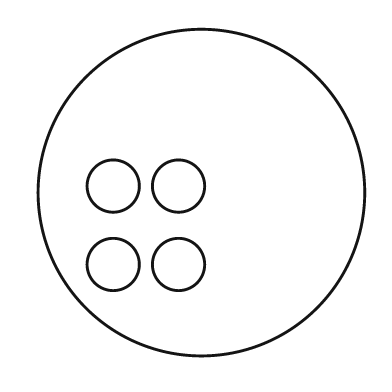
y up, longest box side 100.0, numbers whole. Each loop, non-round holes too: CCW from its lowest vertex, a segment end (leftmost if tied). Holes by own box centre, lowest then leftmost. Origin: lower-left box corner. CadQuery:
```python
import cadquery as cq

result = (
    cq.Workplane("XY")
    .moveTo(50.0, 50.0)
    .circle(50.0)
    .moveTo(23.0, 28.0)
    .circle(8.0)
    .moveTo(43.0, 28.0)
    .circle(8.0)
    .moveTo(23.0, 52.0)
    .circle(8.0)
    .moveTo(43.0, 52.0)
    .circle(8.0)
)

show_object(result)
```